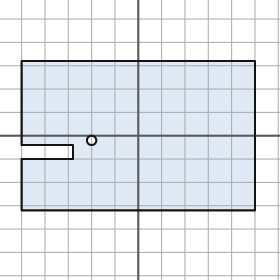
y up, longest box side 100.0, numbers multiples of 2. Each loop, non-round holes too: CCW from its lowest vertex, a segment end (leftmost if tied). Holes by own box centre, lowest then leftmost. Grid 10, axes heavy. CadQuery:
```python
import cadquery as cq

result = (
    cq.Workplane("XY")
    .moveTo(-50.0, -32.0)
    .lineTo(50.0, -32.0)
    .lineTo(50.0, 32.0)
    .lineTo(-50.0, 32.0)
    .lineTo(-50.0, -4.0)
    .lineTo(-28.0, -4.0)
    .lineTo(-28.0, -10.0)
    .lineTo(-50.0, -10.0)
    .close()
    .moveTo(-20.0, -2.0)
    .circle(2.0)
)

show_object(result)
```